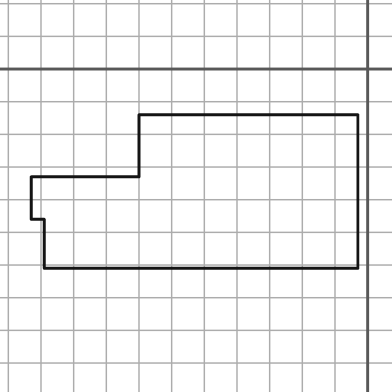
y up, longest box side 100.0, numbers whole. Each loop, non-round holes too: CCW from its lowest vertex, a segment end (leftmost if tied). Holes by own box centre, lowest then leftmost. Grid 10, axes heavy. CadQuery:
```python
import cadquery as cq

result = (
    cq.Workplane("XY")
    .moveTo(-99.0, -61.0)
    .lineTo(-3.0, -61.0)
    .lineTo(-3.0, -14.0)
    .lineTo(-70.0, -14.0)
    .lineTo(-70.0, -33.0)
    .lineTo(-103.0, -33.0)
    .lineTo(-103.0, -46.0)
    .lineTo(-99.0, -46.0)
    .close()
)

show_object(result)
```